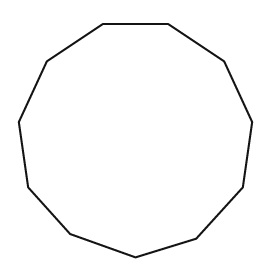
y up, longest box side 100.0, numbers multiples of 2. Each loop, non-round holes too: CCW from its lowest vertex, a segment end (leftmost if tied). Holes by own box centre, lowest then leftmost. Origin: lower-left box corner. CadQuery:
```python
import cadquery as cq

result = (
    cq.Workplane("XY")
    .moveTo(50.0, 0.0)
    .lineTo(76.0, 8.0)
    .lineTo(96.0, 30.0)
    .lineTo(100.0, 58.0)
    .lineTo(88.0, 84.0)
    .lineTo(64.0, 100.0)
    .lineTo(36.0, 100.0)
    .lineTo(12.0, 84.0)
    .lineTo(0.0, 58.0)
    .lineTo(4.0, 30.0)
    .lineTo(22.0, 10.0)
    .close()
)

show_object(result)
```